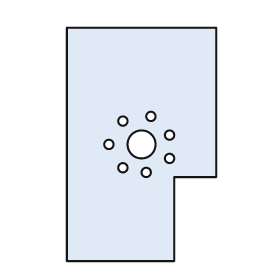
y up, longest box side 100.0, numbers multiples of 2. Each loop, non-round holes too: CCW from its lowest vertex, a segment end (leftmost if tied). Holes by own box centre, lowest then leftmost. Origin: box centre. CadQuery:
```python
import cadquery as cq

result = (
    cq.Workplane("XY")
    .moveTo(-32.0, -50.0)
    .lineTo(14.0, -50.0)
    .lineTo(14.0, -14.0)
    .lineTo(32.0, -14.0)
    .lineTo(32.0, 50.0)
    .lineTo(-32.0, 50.0)
    .close()
    .moveTo(2.0, -12.0)
    .circle(2.0)
    .moveTo(-8.0, -10.0)
    .circle(2.0)
    .moveTo(12.0, -6.0)
    .circle(2.0)
    .moveTo(-14.0, 0.0)
    .circle(2.0)
    .moveTo(0.0, 0.0)
    .circle(6.0)
    .moveTo(12.0, 4.0)
    .circle(2.0)
    .moveTo(-8.0, 10.0)
    .circle(2.0)
    .moveTo(4.0, 12.0)
    .circle(2.0)
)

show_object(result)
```